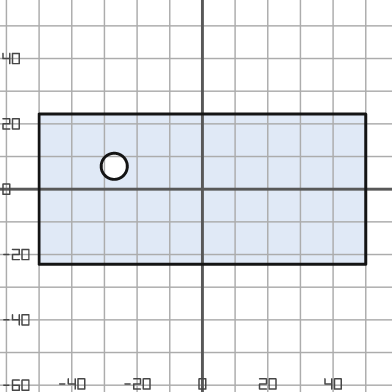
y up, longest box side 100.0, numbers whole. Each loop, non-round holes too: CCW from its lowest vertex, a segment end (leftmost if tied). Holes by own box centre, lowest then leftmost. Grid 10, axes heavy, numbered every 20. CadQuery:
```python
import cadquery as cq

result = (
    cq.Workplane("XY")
    .moveTo(-50.0, -23.0)
    .lineTo(50.0, -23.0)
    .lineTo(50.0, 23.0)
    .lineTo(-50.0, 23.0)
    .close()
    .moveTo(-27.0, 7.0)
    .circle(4.0)
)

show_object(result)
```